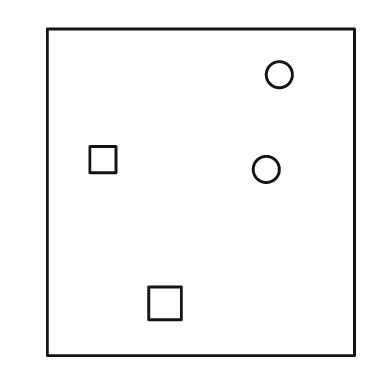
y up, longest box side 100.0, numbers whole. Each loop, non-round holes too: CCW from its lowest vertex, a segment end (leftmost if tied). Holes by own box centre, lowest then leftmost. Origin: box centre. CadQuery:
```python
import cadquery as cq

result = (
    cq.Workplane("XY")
    .moveTo(-47.0, -50.0)
    .lineTo(47.0, -50.0)
    .lineTo(47.0, 50.0)
    .lineTo(-47.0, 50.0)
    .close()
    .moveTo(-16.0, -39.0)
    .lineTo(-6.0, -39.0)
    .lineTo(-6.0, -29.0)
    .lineTo(-16.0, -29.0)
    .close()
    .moveTo(20.0, 7.0)
    .circle(4.0)
    .moveTo(-34.0, 6.0)
    .lineTo(-26.0, 6.0)
    .lineTo(-26.0, 14.0)
    .lineTo(-34.0, 14.0)
    .close()
    .moveTo(24.0, 36.0)
    .circle(4.0)
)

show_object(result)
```